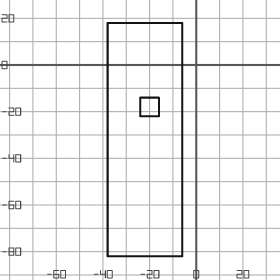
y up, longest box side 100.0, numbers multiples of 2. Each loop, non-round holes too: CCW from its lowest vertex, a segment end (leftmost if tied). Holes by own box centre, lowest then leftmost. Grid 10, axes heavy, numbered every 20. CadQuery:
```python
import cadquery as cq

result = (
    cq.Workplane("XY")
    .moveTo(-38.0, -82.0)
    .lineTo(-6.0, -82.0)
    .lineTo(-6.0, 18.0)
    .lineTo(-38.0, 18.0)
    .close()
    .moveTo(-24.0, -22.0)
    .lineTo(-16.0, -22.0)
    .lineTo(-16.0, -14.0)
    .lineTo(-24.0, -14.0)
    .close()
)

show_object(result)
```